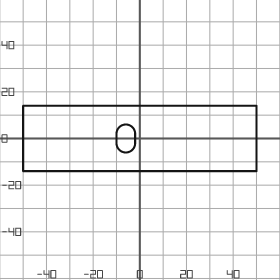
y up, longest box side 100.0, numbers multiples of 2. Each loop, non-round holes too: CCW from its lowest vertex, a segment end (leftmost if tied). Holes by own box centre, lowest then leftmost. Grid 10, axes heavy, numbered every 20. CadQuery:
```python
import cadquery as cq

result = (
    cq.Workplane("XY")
    .moveTo(-50.0, -14.0)
    .lineTo(50.0, -14.0)
    .lineTo(50.0, 14.0)
    .lineTo(-50.0, 14.0)
    .close()
    .moveTo(-10.0, -2.0)
    .threePointArc((-6.0, -6.0), (-2.0, -2.0))
    .lineTo(-2.0, 2.0)
    .threePointArc((-6.0, 6.0), (-10.0, 2.0))
    .close()
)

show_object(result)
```